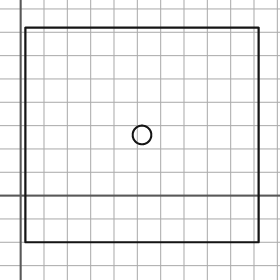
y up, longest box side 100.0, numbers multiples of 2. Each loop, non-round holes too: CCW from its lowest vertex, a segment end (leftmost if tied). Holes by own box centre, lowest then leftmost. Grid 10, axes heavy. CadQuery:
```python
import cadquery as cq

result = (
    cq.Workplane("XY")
    .moveTo(2.0, -20.0)
    .lineTo(102.0, -20.0)
    .lineTo(102.0, 72.0)
    .lineTo(2.0, 72.0)
    .close()
    .moveTo(52.0, 26.0)
    .circle(4.0)
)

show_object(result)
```